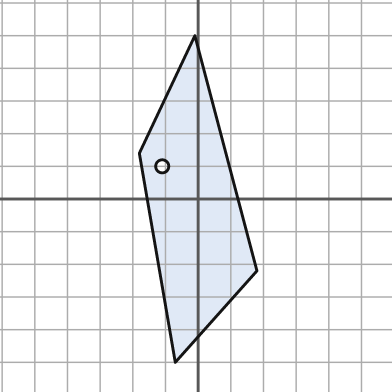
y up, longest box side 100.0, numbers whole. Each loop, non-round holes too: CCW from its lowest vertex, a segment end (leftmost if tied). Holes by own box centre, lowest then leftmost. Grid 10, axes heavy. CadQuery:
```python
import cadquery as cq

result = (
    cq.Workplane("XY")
    .moveTo(-7.0, -50.0)
    .lineTo(18.0, -22.0)
    .lineTo(-1.0, 50.0)
    .lineTo(-18.0, 14.0)
    .close()
    .moveTo(-11.0, 10.0)
    .circle(2.0)
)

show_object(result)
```